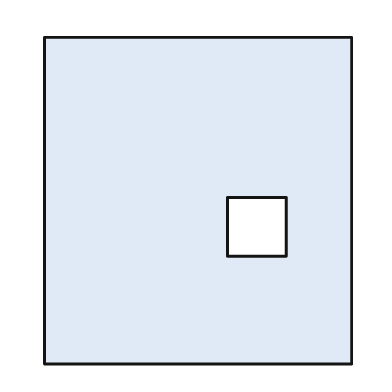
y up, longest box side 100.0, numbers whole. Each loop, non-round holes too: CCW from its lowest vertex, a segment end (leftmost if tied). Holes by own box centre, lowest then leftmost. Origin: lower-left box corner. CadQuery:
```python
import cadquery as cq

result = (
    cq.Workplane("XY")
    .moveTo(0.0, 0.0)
    .lineTo(94.0, 0.0)
    .lineTo(94.0, 100.0)
    .lineTo(0.0, 100.0)
    .close()
    .moveTo(56.0, 33.0)
    .lineTo(74.0, 33.0)
    .lineTo(74.0, 51.0)
    .lineTo(56.0, 51.0)
    .close()
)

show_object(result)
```